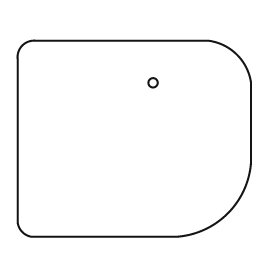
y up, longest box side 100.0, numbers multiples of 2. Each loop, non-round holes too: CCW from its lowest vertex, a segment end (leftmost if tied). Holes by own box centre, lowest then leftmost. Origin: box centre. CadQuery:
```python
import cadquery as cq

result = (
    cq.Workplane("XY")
    .moveTo(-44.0, -42.0)
    .lineTo(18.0, -42.0)
    .threePointArc((40.0, -32.0), (50.0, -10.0))
    .lineTo(50.0, 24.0)
    .threePointArc((44.0, 36.0), (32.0, 42.0))
    .lineTo(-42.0, 42.0)
    .threePointArc((-48.0, 40.0), (-50.0, 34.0))
    .lineTo(-50.0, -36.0)
    .threePointArc((-48.0, -40.0), (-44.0, -42.0))
    .close()
    .moveTo(8.0, 24.0)
    .circle(2.0)
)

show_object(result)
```